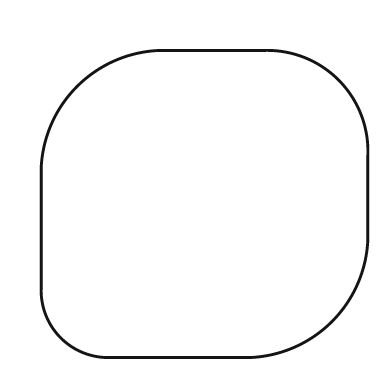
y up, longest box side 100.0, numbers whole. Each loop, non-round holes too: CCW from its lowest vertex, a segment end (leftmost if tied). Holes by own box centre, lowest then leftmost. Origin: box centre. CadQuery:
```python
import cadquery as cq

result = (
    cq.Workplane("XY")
    .moveTo(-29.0, -47.0)
    .lineTo(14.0, -47.0)
    .threePointArc((39.0, -36.0), (50.0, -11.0))
    .lineTo(50.0, 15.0)
    .threePointArc((41.0, 38.0), (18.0, 47.0))
    .lineTo(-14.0, 47.0)
    .threePointArc((-39.0, 36.0), (-50.0, 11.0))
    .lineTo(-50.0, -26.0)
    .threePointArc((-44.0, -41.0), (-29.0, -47.0))
    .close()
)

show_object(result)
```